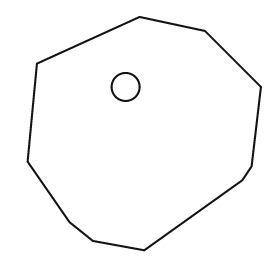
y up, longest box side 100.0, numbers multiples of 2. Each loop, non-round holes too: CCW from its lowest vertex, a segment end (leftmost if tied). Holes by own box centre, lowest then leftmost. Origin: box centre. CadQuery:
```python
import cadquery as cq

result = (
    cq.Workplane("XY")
    .moveTo(0.0, -50.0)
    .lineTo(42.0, -20.0)
    .lineTo(46.0, -14.0)
    .lineTo(50.0, 20.0)
    .lineTo(26.0, 44.0)
    .lineTo(-2.0, 50.0)
    .lineTo(-46.0, 30.0)
    .lineTo(-50.0, -12.0)
    .lineTo(-32.0, -38.0)
    .lineTo(-22.0, -46.0)
    .close()
    .moveTo(-8.0, 20.0)
    .circle(6.0)
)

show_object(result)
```